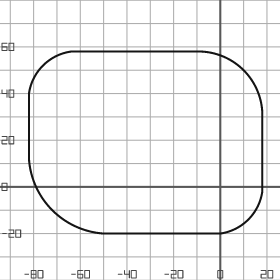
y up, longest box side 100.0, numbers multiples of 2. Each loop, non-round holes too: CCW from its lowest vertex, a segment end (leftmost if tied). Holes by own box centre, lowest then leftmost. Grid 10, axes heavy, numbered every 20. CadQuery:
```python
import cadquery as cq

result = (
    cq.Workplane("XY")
    .moveTo(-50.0, -20.0)
    .lineTo(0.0, -20.0)
    .threePointArc((12.0, -14.0), (18.0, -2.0))
    .lineTo(18.0, 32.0)
    .threePointArc((10.0, 50.0), (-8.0, 58.0))
    .lineTo(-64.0, 58.0)
    .threePointArc((-76.0, 52.0), (-82.0, 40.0))
    .lineTo(-82.0, 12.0)
    .threePointArc((-72.0, -10.0), (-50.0, -20.0))
    .close()
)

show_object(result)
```